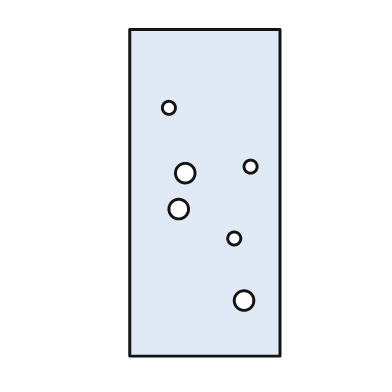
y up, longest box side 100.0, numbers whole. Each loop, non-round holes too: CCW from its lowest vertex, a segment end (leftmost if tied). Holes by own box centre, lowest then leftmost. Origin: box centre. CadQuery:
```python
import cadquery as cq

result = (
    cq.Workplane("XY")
    .moveTo(-23.0, -50.0)
    .lineTo(23.0, -50.0)
    .lineTo(23.0, 50.0)
    .lineTo(-23.0, 50.0)
    .close()
    .moveTo(12.0, -33.0)
    .circle(3.0)
    .moveTo(9.0, -14.0)
    .circle(2.0)
    .moveTo(-8.0, -5.0)
    .circle(3.0)
    .moveTo(-6.0, 6.0)
    .circle(3.0)
    .moveTo(14.0, 8.0)
    .circle(2.0)
    .moveTo(-11.0, 26.0)
    .circle(2.0)
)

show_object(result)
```